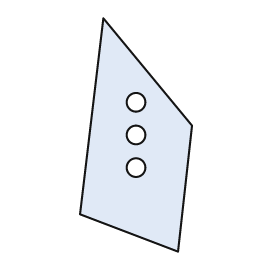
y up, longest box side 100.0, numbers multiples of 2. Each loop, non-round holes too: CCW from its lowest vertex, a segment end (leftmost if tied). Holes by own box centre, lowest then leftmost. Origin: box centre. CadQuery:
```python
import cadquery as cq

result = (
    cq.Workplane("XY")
    .moveTo(18.0, -50.0)
    .lineTo(24.0, 4.0)
    .lineTo(-14.0, 50.0)
    .lineTo(-24.0, -34.0)
    .close()
    .moveTo(0.0, -14.0)
    .circle(4.0)
    .moveTo(0.0, 0.0)
    .circle(4.0)
    .moveTo(0.0, 14.0)
    .circle(4.0)
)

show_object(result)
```